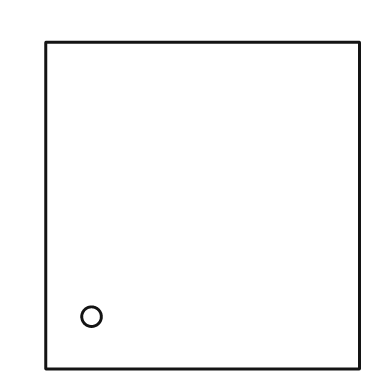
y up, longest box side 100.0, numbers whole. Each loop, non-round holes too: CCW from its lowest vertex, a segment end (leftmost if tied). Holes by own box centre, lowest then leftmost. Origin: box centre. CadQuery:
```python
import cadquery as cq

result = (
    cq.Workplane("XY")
    .moveTo(-48.0, -50.0)
    .lineTo(48.0, -50.0)
    .lineTo(48.0, 50.0)
    .lineTo(-48.0, 50.0)
    .close()
    .moveTo(-34.0, -34.0)
    .circle(3.0)
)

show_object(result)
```